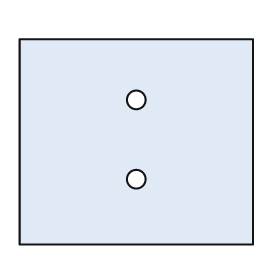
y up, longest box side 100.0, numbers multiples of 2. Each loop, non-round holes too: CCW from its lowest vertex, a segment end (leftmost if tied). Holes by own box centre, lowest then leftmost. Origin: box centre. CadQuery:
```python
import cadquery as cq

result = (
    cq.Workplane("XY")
    .moveTo(-50.0, -44.0)
    .lineTo(50.0, -44.0)
    .lineTo(50.0, 44.0)
    .lineTo(-50.0, 44.0)
    .close()
    .moveTo(0.0, -16.0)
    .circle(4.0)
    .moveTo(0.0, 18.0)
    .circle(4.0)
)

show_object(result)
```